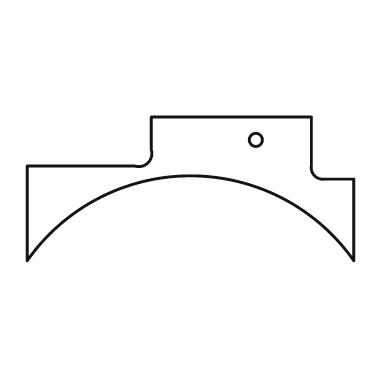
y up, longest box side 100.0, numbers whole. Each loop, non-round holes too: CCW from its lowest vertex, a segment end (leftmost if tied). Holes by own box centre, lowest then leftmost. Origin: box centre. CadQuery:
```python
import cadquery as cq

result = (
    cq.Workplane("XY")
    .moveTo(-50.0, -22.0)
    .threePointArc((0.0, 4.0), (50.0, -22.0))
    .lineTo(50.0, 3.0)
    .lineTo(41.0, 3.0)
    .threePointArc((38.0, 4.0), (37.0, 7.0))
    .lineTo(37.0, 22.0)
    .lineTo(-12.0, 22.0)
    .lineTo(-12.0, 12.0)
    .threePointArc((-13.0, 8.0), (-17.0, 7.0))
    .lineTo(-50.0, 7.0)
    .close()
    .moveTo(20.0, 15.0)
    .circle(2.0)
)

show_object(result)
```